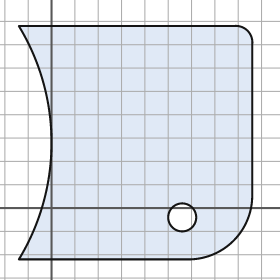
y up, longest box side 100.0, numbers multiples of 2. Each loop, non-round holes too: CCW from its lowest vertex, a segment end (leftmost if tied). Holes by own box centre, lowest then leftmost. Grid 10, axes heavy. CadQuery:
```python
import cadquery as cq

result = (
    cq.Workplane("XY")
    .moveTo(-14.0, -22.0)
    .lineTo(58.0, -22.0)
    .threePointArc((78.0, -14.0), (86.0, 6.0))
    .lineTo(86.0, 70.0)
    .threePointArc((84.0, 76.0), (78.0, 78.0))
    .lineTo(-14.0, 78.0)
    .threePointArc((0.0, 28.0), (-14.0, -22.0))
    .close()
    .moveTo(56.0, -4.0)
    .circle(6.0)
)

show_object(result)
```